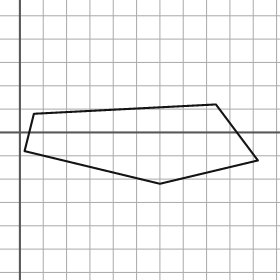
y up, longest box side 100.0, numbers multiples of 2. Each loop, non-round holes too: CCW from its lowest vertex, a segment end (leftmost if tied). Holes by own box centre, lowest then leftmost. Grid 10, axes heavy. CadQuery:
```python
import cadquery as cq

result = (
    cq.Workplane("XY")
    .moveTo(60.0, -22.0)
    .lineTo(102.0, -12.0)
    .lineTo(84.0, 12.0)
    .lineTo(6.0, 8.0)
    .lineTo(2.0, -8.0)
    .close()
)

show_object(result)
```